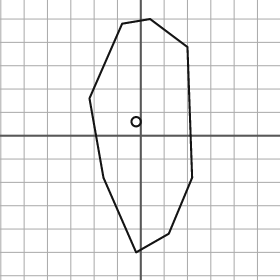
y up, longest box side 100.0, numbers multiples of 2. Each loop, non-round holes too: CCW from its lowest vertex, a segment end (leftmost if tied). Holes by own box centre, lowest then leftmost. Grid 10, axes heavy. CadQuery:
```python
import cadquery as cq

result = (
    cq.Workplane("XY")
    .moveTo(-2.0, -50.0)
    .lineTo(12.0, -42.0)
    .lineTo(22.0, -18.0)
    .lineTo(20.0, 38.0)
    .lineTo(4.0, 50.0)
    .lineTo(-8.0, 48.0)
    .lineTo(-22.0, 16.0)
    .lineTo(-16.0, -18.0)
    .close()
    .moveTo(-2.0, 6.0)
    .circle(2.0)
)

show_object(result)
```